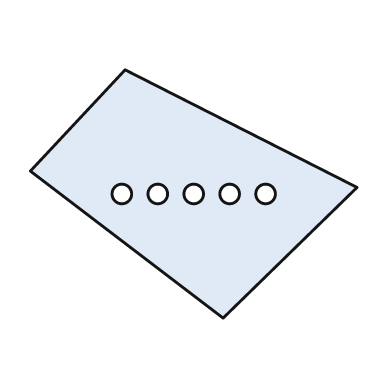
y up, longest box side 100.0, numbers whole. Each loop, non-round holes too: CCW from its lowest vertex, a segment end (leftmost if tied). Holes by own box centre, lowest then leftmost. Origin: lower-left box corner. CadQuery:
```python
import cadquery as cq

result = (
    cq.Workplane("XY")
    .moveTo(59.0, 0.0)
    .lineTo(100.0, 40.0)
    .lineTo(29.0, 76.0)
    .lineTo(0.0, 45.0)
    .close()
    .moveTo(28.0, 38.0)
    .circle(3.0)
    .moveTo(39.0, 38.0)
    .circle(3.0)
    .moveTo(50.0, 38.0)
    .circle(3.0)
    .moveTo(61.0, 38.0)
    .circle(3.0)
    .moveTo(72.0, 38.0)
    .circle(3.0)
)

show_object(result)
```